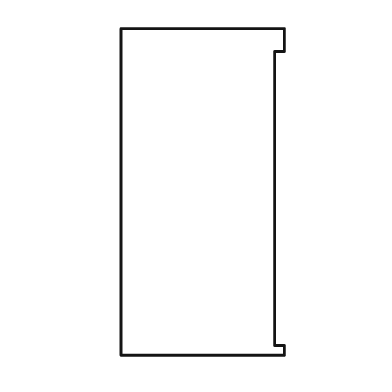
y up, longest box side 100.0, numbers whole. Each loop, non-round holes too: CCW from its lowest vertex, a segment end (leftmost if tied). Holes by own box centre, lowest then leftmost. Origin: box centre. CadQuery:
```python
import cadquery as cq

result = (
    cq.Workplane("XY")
    .moveTo(-25.0, -50.0)
    .lineTo(25.0, -50.0)
    .lineTo(25.0, -47.0)
    .lineTo(22.0, -47.0)
    .lineTo(22.0, 43.0)
    .lineTo(25.0, 43.0)
    .lineTo(25.0, 50.0)
    .lineTo(-25.0, 50.0)
    .close()
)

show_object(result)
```